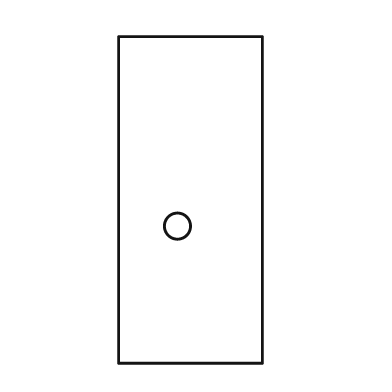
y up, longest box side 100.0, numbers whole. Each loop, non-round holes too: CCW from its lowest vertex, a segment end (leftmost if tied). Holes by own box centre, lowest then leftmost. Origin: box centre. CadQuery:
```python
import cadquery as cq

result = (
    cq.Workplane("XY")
    .moveTo(-22.0, -50.0)
    .lineTo(22.0, -50.0)
    .lineTo(22.0, 50.0)
    .lineTo(-22.0, 50.0)
    .close()
    .moveTo(-4.0, -8.0)
    .circle(4.0)
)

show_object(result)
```